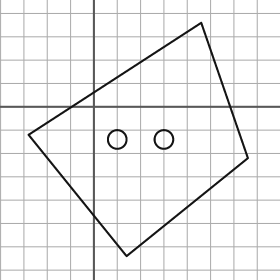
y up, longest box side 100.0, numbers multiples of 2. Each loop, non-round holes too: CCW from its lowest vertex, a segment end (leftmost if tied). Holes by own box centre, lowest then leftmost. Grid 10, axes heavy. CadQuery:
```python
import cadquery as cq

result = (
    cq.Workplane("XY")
    .moveTo(14.0, -64.0)
    .lineTo(66.0, -22.0)
    .lineTo(46.0, 36.0)
    .lineTo(-28.0, -12.0)
    .close()
    .moveTo(10.0, -14.0)
    .circle(4.0)
    .moveTo(30.0, -14.0)
    .circle(4.0)
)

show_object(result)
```